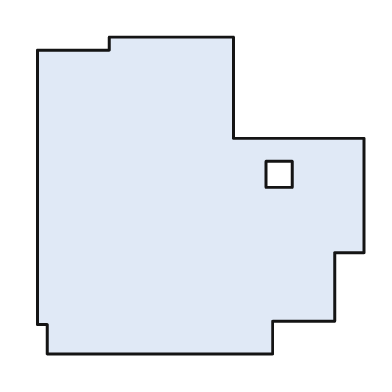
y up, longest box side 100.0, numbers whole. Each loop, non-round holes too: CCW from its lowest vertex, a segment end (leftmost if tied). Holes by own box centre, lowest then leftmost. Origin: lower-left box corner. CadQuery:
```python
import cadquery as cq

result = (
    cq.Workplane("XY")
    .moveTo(3.0, 0.0)
    .lineTo(72.0, 0.0)
    .lineTo(72.0, 10.0)
    .lineTo(91.0, 10.0)
    .lineTo(91.0, 31.0)
    .lineTo(100.0, 31.0)
    .lineTo(100.0, 66.0)
    .lineTo(60.0, 66.0)
    .lineTo(60.0, 97.0)
    .lineTo(22.0, 97.0)
    .lineTo(22.0, 93.0)
    .lineTo(0.0, 93.0)
    .lineTo(0.0, 9.0)
    .lineTo(3.0, 9.0)
    .close()
    .moveTo(70.0, 51.0)
    .lineTo(78.0, 51.0)
    .lineTo(78.0, 59.0)
    .lineTo(70.0, 59.0)
    .close()
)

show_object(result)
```